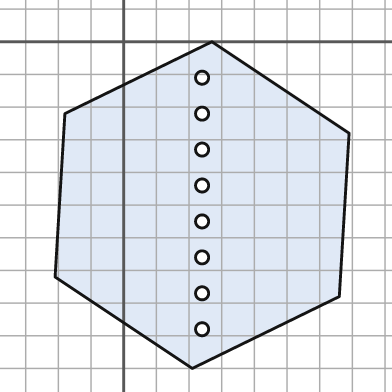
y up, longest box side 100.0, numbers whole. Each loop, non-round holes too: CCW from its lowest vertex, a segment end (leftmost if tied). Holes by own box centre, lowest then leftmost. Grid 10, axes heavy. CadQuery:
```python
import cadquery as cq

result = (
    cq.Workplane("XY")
    .moveTo(21.0, -100.0)
    .lineTo(66.0, -78.0)
    .lineTo(69.0, -28.0)
    .lineTo(27.0, 0.0)
    .lineTo(-18.0, -22.0)
    .lineTo(-21.0, -72.0)
    .close()
    .moveTo(24.0, -88.0)
    .circle(2.0)
    .moveTo(24.0, -77.0)
    .circle(2.0)
    .moveTo(24.0, -66.0)
    .circle(2.0)
    .moveTo(24.0, -55.0)
    .circle(2.0)
    .moveTo(24.0, -44.0)
    .circle(2.0)
    .moveTo(24.0, -33.0)
    .circle(2.0)
    .moveTo(24.0, -22.0)
    .circle(2.0)
    .moveTo(24.0, -11.0)
    .circle(2.0)
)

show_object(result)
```